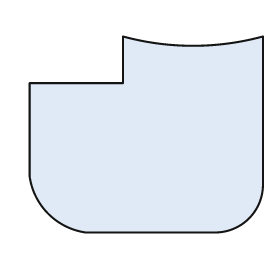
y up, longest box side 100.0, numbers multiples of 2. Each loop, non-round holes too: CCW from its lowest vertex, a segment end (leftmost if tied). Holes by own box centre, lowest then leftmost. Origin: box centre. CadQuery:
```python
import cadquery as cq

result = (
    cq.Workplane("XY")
    .moveTo(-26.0, -42.0)
    .lineTo(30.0, -42.0)
    .threePointArc((44.0, -36.0), (50.0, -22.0))
    .lineTo(50.0, 42.0)
    .threePointArc((20.0, 38.0), (-10.0, 42.0))
    .lineTo(-10.0, 22.0)
    .lineTo(-50.0, 22.0)
    .lineTo(-50.0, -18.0)
    .threePointArc((-42.0, -34.0), (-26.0, -42.0))
    .close()
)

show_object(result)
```